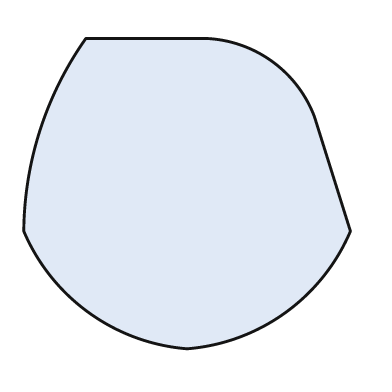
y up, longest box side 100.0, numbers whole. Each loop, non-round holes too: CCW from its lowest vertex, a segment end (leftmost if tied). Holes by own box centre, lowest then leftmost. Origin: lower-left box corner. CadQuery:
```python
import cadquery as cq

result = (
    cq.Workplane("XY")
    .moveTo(50.0, 0.0)
    .threePointArc((80.0, 11.0), (100.0, 36.0))
    .lineTo(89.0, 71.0)
    .threePointArc((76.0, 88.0), (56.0, 95.0))
    .lineTo(19.0, 95.0)
    .threePointArc((5.0, 67.0), (0.0, 36.0))
    .threePointArc((20.0, 11.0), (50.0, 0.0))
    .close()
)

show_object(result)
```